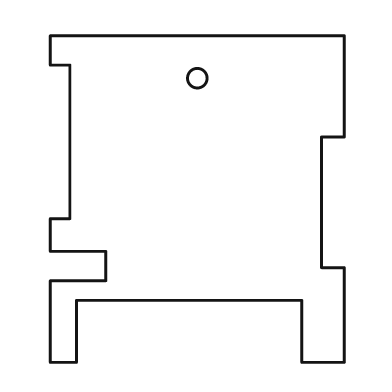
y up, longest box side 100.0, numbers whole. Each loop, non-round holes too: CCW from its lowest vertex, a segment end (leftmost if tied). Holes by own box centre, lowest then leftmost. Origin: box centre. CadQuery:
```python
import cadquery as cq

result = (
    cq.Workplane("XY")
    .moveTo(-45.0, -50.0)
    .lineTo(-37.0, -50.0)
    .lineTo(-37.0, -31.0)
    .lineTo(32.0, -31.0)
    .lineTo(32.0, -50.0)
    .lineTo(45.0, -50.0)
    .lineTo(45.0, -21.0)
    .lineTo(38.0, -21.0)
    .lineTo(38.0, 19.0)
    .lineTo(45.0, 19.0)
    .lineTo(45.0, 50.0)
    .lineTo(-45.0, 50.0)
    .lineTo(-45.0, 41.0)
    .lineTo(-39.0, 41.0)
    .lineTo(-39.0, -6.0)
    .lineTo(-45.0, -6.0)
    .lineTo(-45.0, -16.0)
    .lineTo(-28.0, -16.0)
    .lineTo(-28.0, -25.0)
    .lineTo(-45.0, -25.0)
    .close()
    .moveTo(0.0, 37.0)
    .circle(3.0)
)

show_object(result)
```